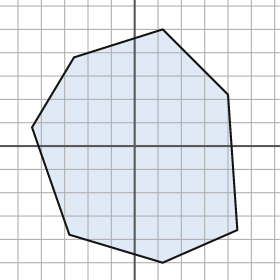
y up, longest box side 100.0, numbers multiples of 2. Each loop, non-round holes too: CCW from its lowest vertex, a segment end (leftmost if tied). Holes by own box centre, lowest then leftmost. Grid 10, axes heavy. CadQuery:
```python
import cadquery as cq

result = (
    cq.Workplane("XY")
    .moveTo(12.0, -50.0)
    .lineTo(44.0, -36.0)
    .lineTo(40.0, 22.0)
    .lineTo(12.0, 50.0)
    .lineTo(-26.0, 38.0)
    .lineTo(-44.0, 8.0)
    .lineTo(-28.0, -38.0)
    .close()
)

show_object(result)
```